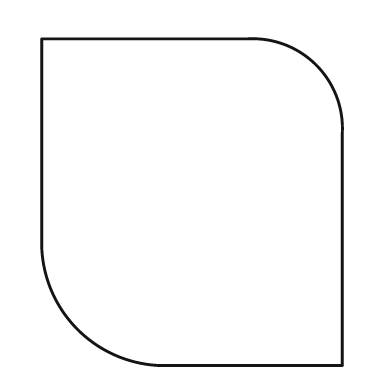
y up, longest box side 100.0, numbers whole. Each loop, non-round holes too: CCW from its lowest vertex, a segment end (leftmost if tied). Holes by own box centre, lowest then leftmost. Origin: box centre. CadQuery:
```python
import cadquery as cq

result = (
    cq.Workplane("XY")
    .moveTo(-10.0, -50.0)
    .lineTo(46.0, -50.0)
    .lineTo(46.0, 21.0)
    .threePointArc((38.0, 42.0), (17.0, 50.0))
    .lineTo(-46.0, 50.0)
    .lineTo(-46.0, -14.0)
    .threePointArc((-35.0, -39.0), (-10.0, -50.0))
    .close()
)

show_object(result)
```